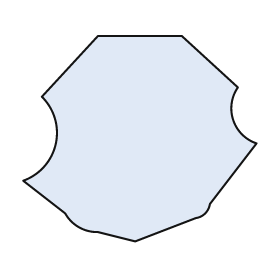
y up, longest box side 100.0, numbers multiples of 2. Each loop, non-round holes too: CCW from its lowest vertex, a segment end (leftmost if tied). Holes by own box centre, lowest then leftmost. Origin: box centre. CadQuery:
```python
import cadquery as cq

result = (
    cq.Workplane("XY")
    .moveTo(-2.0, -44.0)
    .lineTo(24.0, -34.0)
    .threePointArc((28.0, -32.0), (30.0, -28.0))
    .lineTo(50.0, -2.0)
    .threePointArc((40.0, 8.0), (42.0, 22.0))
    .lineTo(18.0, 44.0)
    .lineTo(-18.0, 44.0)
    .lineTo(-42.0, 18.0)
    .threePointArc((-36.0, -2.0), (-50.0, -18.0))
    .lineTo(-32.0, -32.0)
    .threePointArc((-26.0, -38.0), (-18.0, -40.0))
    .close()
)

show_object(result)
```